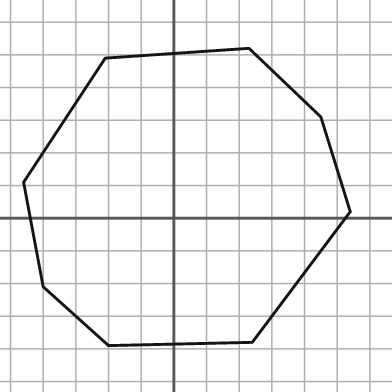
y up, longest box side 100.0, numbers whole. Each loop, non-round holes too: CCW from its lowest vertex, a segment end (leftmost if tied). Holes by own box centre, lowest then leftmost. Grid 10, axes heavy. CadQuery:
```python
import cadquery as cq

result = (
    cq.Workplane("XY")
    .moveTo(-20.0, -39.0)
    .lineTo(24.0, -38.0)
    .lineTo(54.0, 2.0)
    .lineTo(45.0, 31.0)
    .lineTo(23.0, 52.0)
    .lineTo(-21.0, 49.0)
    .lineTo(-46.0, 11.0)
    .lineTo(-40.0, -21.0)
    .close()
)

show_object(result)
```